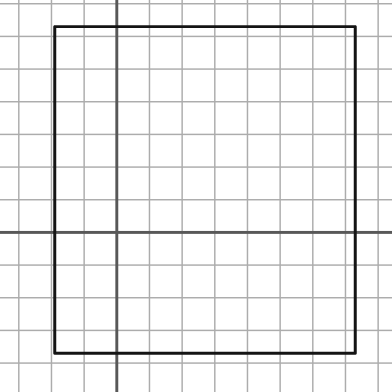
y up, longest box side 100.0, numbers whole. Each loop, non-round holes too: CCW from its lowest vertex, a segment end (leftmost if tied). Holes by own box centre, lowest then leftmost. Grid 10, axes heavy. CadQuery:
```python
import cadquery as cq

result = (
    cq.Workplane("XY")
    .moveTo(-19.0, -37.0)
    .lineTo(73.0, -37.0)
    .lineTo(73.0, 63.0)
    .lineTo(-19.0, 63.0)
    .close()
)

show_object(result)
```